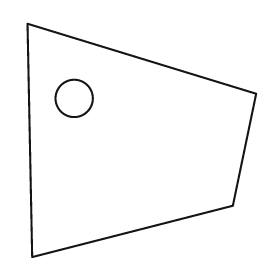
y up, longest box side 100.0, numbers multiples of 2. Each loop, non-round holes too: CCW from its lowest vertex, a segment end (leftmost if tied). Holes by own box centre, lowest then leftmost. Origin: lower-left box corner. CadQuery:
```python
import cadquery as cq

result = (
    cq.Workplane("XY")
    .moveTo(2.0, 0.0)
    .lineTo(88.0, 22.0)
    .lineTo(98.0, 70.0)
    .lineTo(0.0, 100.0)
    .close()
    .moveTo(20.0, 68.0)
    .circle(8.0)
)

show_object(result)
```